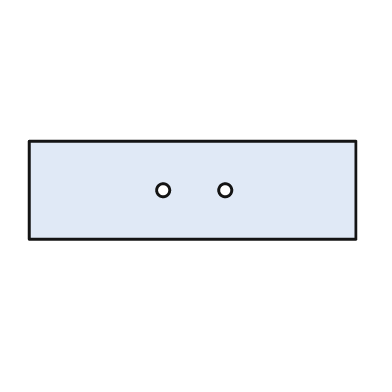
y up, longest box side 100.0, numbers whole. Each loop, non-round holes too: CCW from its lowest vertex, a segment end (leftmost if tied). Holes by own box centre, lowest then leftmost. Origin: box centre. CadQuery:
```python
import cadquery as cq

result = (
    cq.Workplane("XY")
    .moveTo(-50.0, -15.0)
    .lineTo(50.0, -15.0)
    .lineTo(50.0, 15.0)
    .lineTo(-50.0, 15.0)
    .close()
    .moveTo(-9.0, 0.0)
    .circle(2.0)
    .moveTo(10.0, 0.0)
    .circle(2.0)
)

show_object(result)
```